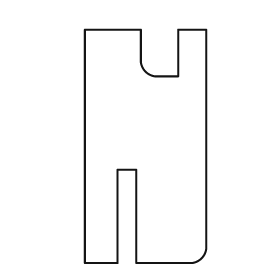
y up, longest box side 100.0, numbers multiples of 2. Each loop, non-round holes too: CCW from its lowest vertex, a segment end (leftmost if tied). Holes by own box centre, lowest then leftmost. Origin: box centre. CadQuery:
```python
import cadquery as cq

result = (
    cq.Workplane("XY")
    .moveTo(-26.0, -50.0)
    .lineTo(-12.0, -50.0)
    .lineTo(-12.0, -10.0)
    .lineTo(-4.0, -10.0)
    .lineTo(-4.0, -50.0)
    .lineTo(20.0, -50.0)
    .threePointArc((24.0, -48.0), (26.0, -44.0))
    .lineTo(26.0, 50.0)
    .lineTo(14.0, 50.0)
    .lineTo(14.0, 30.0)
    .lineTo(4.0, 30.0)
    .threePointArc((0.0, 32.0), (-2.0, 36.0))
    .lineTo(-2.0, 50.0)
    .lineTo(-26.0, 50.0)
    .close()
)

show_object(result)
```